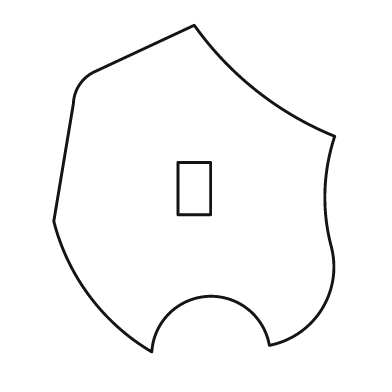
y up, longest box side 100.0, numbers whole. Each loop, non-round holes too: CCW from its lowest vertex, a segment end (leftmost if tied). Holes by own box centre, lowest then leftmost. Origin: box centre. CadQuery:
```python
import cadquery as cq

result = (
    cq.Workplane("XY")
    .moveTo(-13.0, -50.0)
    .threePointArc((4.0, -33.0), (23.0, -48.0))
    .threePointArc((39.0, -37.0), (42.0, -18.0))
    .threePointArc((40.0, -1.0), (43.0, 16.0))
    .threePointArc((19.0, 30.0), (0.0, 50.0))
    .lineTo(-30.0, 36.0)
    .threePointArc((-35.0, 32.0), (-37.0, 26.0))
    .lineTo(-43.0, -10.0)
    .threePointArc((-32.0, -33.0), (-13.0, -50.0))
    .close()
    .moveTo(-5.0, -8.0)
    .lineTo(5.0, -8.0)
    .lineTo(5.0, 8.0)
    .lineTo(-5.0, 8.0)
    .close()
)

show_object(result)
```